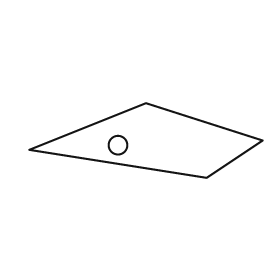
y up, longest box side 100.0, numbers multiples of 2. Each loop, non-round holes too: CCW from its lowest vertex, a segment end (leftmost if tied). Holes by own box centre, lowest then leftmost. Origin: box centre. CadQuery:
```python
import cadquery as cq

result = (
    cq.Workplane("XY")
    .moveTo(26.0, -16.0)
    .lineTo(50.0, 0.0)
    .lineTo(0.0, 16.0)
    .lineTo(-50.0, -4.0)
    .close()
    .moveTo(-12.0, -2.0)
    .circle(4.0)
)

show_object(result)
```